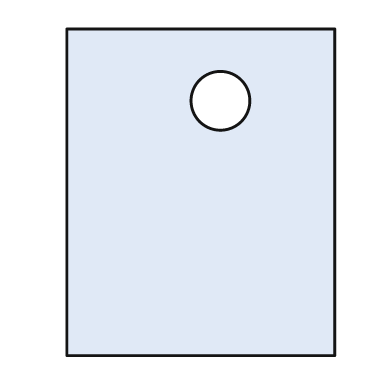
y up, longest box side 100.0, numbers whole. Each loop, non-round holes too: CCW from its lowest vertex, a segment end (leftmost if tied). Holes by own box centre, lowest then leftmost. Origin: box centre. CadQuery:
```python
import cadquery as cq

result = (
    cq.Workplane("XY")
    .moveTo(-41.0, -50.0)
    .lineTo(41.0, -50.0)
    .lineTo(41.0, 50.0)
    .lineTo(-41.0, 50.0)
    .close()
    .moveTo(6.0, 28.0)
    .circle(9.0)
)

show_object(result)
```